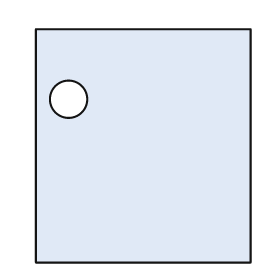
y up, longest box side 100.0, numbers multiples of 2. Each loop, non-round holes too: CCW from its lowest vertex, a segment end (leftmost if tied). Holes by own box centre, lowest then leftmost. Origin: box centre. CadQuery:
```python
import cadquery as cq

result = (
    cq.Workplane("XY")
    .moveTo(-46.0, -50.0)
    .lineTo(46.0, -50.0)
    .lineTo(46.0, 50.0)
    .lineTo(-46.0, 50.0)
    .close()
    .moveTo(-32.0, 20.0)
    .circle(8.0)
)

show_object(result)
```